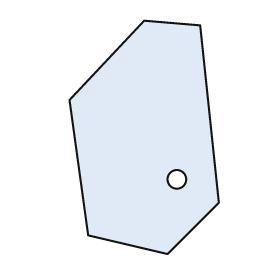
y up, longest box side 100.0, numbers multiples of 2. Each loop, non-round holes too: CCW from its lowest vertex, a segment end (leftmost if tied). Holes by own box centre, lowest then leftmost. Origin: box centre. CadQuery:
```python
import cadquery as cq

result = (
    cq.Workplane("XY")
    .moveTo(10.0, -50.0)
    .lineTo(32.0, -28.0)
    .lineTo(24.0, 48.0)
    .lineTo(0.0, 50.0)
    .lineTo(-32.0, 16.0)
    .lineTo(-24.0, -42.0)
    .close()
    .moveTo(14.0, -18.0)
    .circle(4.0)
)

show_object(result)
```